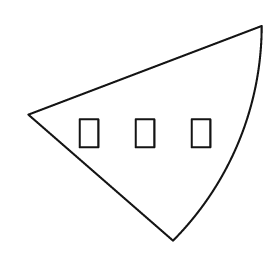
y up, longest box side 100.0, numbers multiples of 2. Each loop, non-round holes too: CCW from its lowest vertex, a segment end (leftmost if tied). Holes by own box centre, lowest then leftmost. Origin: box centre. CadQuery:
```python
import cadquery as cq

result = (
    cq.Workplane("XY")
    .moveTo(12.0, -46.0)
    .threePointArc((40.0, -4.0), (50.0, 46.0))
    .lineTo(-50.0, 8.0)
    .close()
    .moveTo(-28.0, -6.0)
    .lineTo(-20.0, -6.0)
    .lineTo(-20.0, 6.0)
    .lineTo(-28.0, 6.0)
    .close()
    .moveTo(-4.0, -6.0)
    .lineTo(4.0, -6.0)
    .lineTo(4.0, 6.0)
    .lineTo(-4.0, 6.0)
    .close()
    .moveTo(20.0, -6.0)
    .lineTo(28.0, -6.0)
    .lineTo(28.0, 6.0)
    .lineTo(20.0, 6.0)
    .close()
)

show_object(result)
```